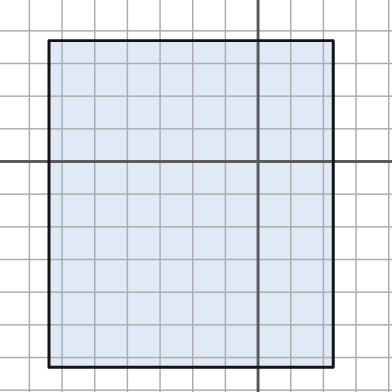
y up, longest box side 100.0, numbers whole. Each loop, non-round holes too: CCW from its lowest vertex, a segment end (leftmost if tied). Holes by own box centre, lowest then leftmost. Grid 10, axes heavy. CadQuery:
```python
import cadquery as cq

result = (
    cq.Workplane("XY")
    .moveTo(-64.0, -63.0)
    .lineTo(23.0, -63.0)
    .lineTo(23.0, 37.0)
    .lineTo(-64.0, 37.0)
    .close()
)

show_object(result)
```